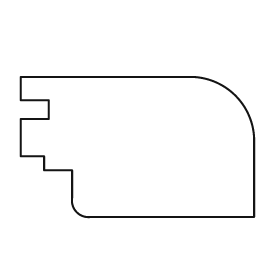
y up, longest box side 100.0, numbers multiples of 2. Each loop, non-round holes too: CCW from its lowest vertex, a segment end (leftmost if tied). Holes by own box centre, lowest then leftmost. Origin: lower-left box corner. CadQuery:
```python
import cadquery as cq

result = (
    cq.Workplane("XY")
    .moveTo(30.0, 0.0)
    .lineTo(100.0, 0.0)
    .lineTo(100.0, 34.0)
    .threePointArc((92.0, 52.0), (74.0, 60.0))
    .lineTo(0.0, 60.0)
    .lineTo(0.0, 50.0)
    .lineTo(12.0, 50.0)
    .lineTo(12.0, 42.0)
    .lineTo(0.0, 42.0)
    .lineTo(0.0, 26.0)
    .lineTo(10.0, 26.0)
    .lineTo(10.0, 20.0)
    .lineTo(22.0, 20.0)
    .lineTo(22.0, 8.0)
    .threePointArc((24.0, 2.0), (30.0, 0.0))
    .close()
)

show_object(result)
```